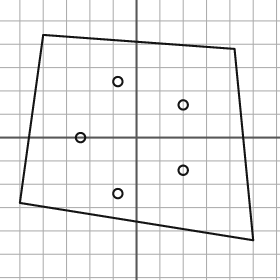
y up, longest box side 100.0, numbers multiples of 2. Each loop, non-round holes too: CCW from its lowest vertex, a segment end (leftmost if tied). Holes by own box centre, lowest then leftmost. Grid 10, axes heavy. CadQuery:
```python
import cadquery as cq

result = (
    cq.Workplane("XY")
    .moveTo(50.0, -44.0)
    .lineTo(42.0, 38.0)
    .lineTo(-40.0, 44.0)
    .lineTo(-50.0, -28.0)
    .close()
    .moveTo(-8.0, -24.0)
    .circle(2.0)
    .moveTo(20.0, -14.0)
    .circle(2.0)
    .moveTo(-24.0, 0.0)
    .circle(2.0)
    .moveTo(20.0, 14.0)
    .circle(2.0)
    .moveTo(-8.0, 24.0)
    .circle(2.0)
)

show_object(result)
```